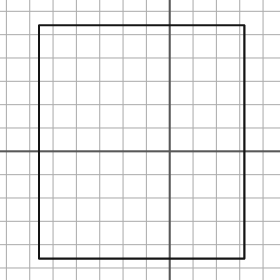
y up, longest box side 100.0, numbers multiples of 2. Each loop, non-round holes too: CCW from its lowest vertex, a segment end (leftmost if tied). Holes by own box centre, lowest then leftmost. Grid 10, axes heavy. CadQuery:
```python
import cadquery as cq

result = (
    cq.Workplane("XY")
    .moveTo(-56.0, -46.0)
    .lineTo(32.0, -46.0)
    .lineTo(32.0, 54.0)
    .lineTo(-56.0, 54.0)
    .close()
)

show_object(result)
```